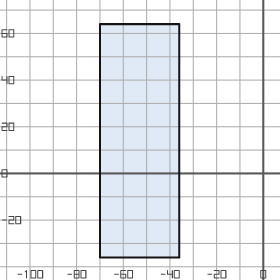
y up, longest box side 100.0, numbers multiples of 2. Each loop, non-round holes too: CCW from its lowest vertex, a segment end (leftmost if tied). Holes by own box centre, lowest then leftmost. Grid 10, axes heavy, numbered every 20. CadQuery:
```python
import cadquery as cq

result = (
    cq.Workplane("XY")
    .moveTo(-70.0, -36.0)
    .lineTo(-36.0, -36.0)
    .lineTo(-36.0, 64.0)
    .lineTo(-70.0, 64.0)
    .close()
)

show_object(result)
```